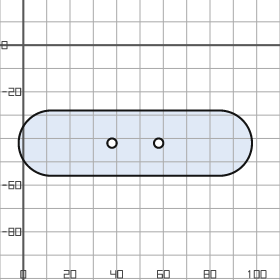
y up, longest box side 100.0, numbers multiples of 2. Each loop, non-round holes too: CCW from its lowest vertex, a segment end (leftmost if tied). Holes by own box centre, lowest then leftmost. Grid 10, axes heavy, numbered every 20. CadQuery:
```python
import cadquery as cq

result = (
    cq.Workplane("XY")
    .moveTo(12.0, -56.0)
    .lineTo(84.0, -56.0)
    .threePointArc((98.0, -42.0), (84.0, -28.0))
    .lineTo(12.0, -28.0)
    .threePointArc((-2.0, -42.0), (12.0, -56.0))
    .close()
    .moveTo(38.0, -42.0)
    .circle(2.0)
    .moveTo(58.0, -42.0)
    .circle(2.0)
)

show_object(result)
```